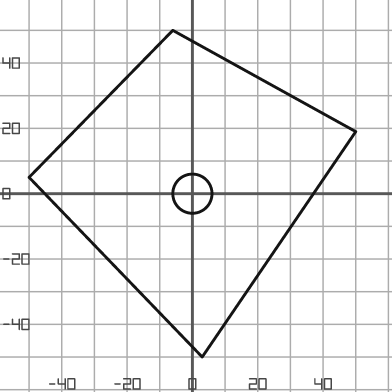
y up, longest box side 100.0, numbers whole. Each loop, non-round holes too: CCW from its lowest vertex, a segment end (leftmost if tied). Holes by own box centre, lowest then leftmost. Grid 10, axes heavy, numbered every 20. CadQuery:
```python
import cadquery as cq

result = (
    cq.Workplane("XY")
    .moveTo(3.0, -50.0)
    .lineTo(50.0, 19.0)
    .lineTo(-6.0, 50.0)
    .lineTo(-50.0, 5.0)
    .close()
    .moveTo(0.0, 0.0)
    .circle(6.0)
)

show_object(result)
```